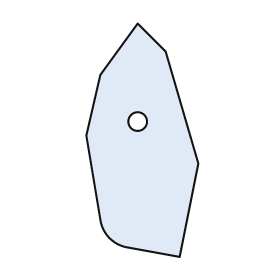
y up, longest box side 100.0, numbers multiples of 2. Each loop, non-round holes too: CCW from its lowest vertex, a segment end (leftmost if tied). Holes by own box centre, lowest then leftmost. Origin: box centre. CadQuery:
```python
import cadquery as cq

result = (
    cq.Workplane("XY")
    .moveTo(16.0, -50.0)
    .lineTo(24.0, -10.0)
    .lineTo(10.0, 38.0)
    .lineTo(-2.0, 50.0)
    .lineTo(-18.0, 28.0)
    .lineTo(-24.0, 2.0)
    .lineTo(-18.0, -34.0)
    .threePointArc((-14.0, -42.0), (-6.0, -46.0))
    .close()
    .moveTo(-2.0, 8.0)
    .circle(4.0)
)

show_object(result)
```